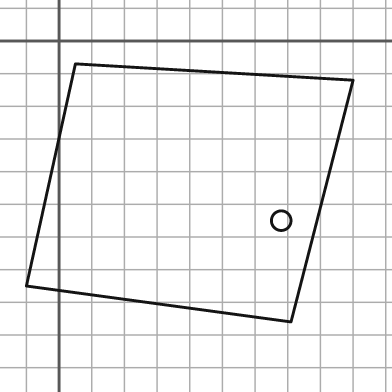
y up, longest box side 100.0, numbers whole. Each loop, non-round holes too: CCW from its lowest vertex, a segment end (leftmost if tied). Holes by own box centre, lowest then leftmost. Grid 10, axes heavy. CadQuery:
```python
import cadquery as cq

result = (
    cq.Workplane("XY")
    .moveTo(71.0, -86.0)
    .lineTo(90.0, -12.0)
    .lineTo(5.0, -7.0)
    .lineTo(-10.0, -75.0)
    .close()
    .moveTo(68.0, -55.0)
    .circle(3.0)
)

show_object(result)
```